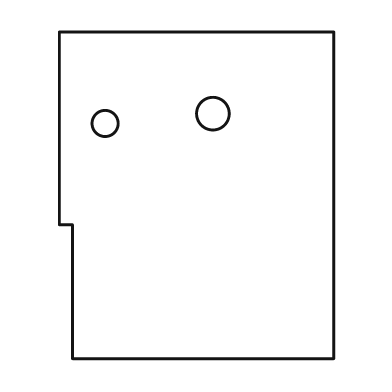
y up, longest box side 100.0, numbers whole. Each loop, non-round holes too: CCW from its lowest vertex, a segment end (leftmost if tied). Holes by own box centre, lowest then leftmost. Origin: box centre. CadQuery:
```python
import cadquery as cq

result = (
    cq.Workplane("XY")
    .moveTo(-38.0, -50.0)
    .lineTo(42.0, -50.0)
    .lineTo(42.0, 50.0)
    .lineTo(-42.0, 50.0)
    .lineTo(-42.0, -9.0)
    .lineTo(-38.0, -9.0)
    .close()
    .moveTo(-28.0, 22.0)
    .circle(4.0)
    .moveTo(5.0, 25.0)
    .circle(5.0)
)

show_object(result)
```